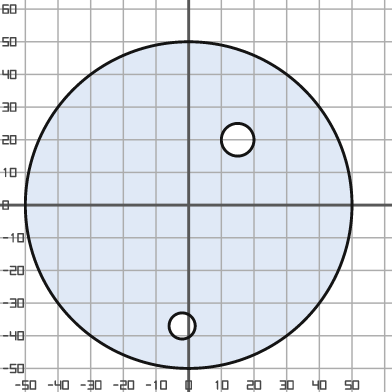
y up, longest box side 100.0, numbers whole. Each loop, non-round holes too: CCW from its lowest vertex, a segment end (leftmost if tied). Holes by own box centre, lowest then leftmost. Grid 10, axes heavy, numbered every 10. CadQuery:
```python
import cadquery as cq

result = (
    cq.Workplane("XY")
    .moveTo(0.0, 0.0)
    .circle(50.0)
    .moveTo(-2.0, -37.0)
    .circle(4.0)
    .moveTo(15.0, 20.0)
    .circle(5.0)
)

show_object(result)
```